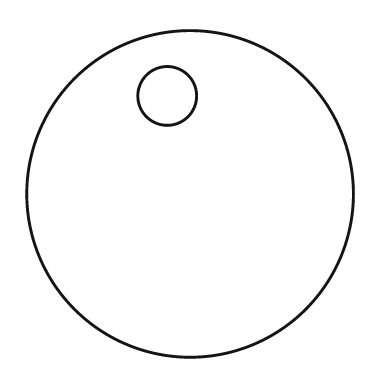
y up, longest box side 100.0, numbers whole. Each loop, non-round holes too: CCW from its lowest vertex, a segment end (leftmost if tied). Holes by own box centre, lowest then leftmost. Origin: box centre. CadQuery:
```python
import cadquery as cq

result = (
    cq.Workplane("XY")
    .moveTo(0.0, 0.0)
    .circle(50.0)
    .moveTo(-7.0, 30.0)
    .circle(9.0)
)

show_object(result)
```